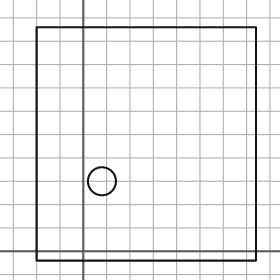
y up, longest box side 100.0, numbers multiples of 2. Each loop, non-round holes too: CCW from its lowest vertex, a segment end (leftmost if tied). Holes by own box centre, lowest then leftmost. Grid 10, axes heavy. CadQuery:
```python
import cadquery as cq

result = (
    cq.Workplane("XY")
    .moveTo(-20.0, -4.0)
    .lineTo(74.0, -4.0)
    .lineTo(74.0, 96.0)
    .lineTo(-20.0, 96.0)
    .close()
    .moveTo(8.0, 30.0)
    .circle(6.0)
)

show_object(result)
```